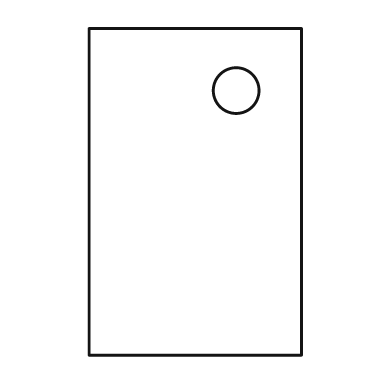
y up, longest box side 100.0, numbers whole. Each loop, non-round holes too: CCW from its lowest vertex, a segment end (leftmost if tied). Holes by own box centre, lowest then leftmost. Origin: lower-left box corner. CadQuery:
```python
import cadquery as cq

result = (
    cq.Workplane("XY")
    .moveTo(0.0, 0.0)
    .lineTo(65.0, 0.0)
    .lineTo(65.0, 100.0)
    .lineTo(0.0, 100.0)
    .close()
    .moveTo(45.0, 81.0)
    .circle(7.0)
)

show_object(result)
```